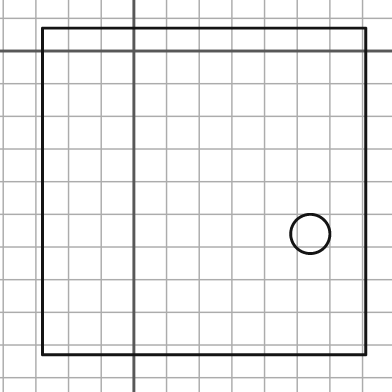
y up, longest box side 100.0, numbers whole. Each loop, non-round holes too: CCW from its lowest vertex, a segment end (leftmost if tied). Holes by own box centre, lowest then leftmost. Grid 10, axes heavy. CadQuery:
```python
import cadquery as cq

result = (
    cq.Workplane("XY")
    .moveTo(-28.0, -93.0)
    .lineTo(71.0, -93.0)
    .lineTo(71.0, 7.0)
    .lineTo(-28.0, 7.0)
    .close()
    .moveTo(54.0, -56.0)
    .circle(6.0)
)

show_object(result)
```